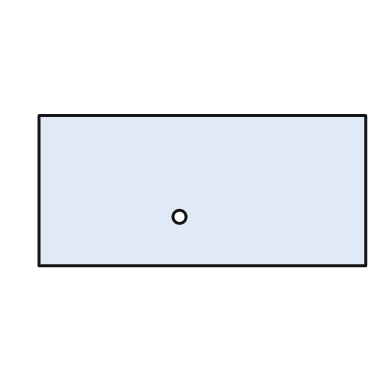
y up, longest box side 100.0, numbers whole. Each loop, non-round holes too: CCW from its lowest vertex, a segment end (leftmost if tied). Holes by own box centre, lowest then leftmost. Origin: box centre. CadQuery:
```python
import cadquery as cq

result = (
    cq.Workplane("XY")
    .moveTo(-50.0, -23.0)
    .lineTo(50.0, -23.0)
    .lineTo(50.0, 23.0)
    .lineTo(-50.0, 23.0)
    .close()
    .moveTo(-7.0, -8.0)
    .circle(2.0)
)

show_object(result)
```